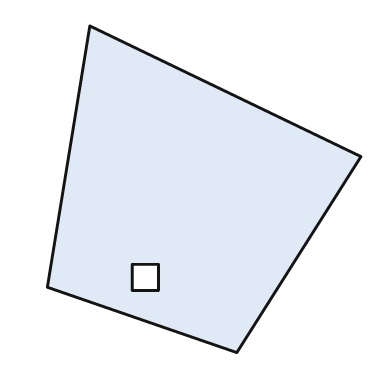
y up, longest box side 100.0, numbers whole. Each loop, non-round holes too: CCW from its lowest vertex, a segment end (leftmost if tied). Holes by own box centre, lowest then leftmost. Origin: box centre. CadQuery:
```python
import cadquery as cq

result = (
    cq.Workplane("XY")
    .moveTo(10.0, -50.0)
    .lineTo(48.0, 10.0)
    .lineTo(-35.0, 50.0)
    .lineTo(-48.0, -30.0)
    .close()
    .moveTo(-22.0, -31.0)
    .lineTo(-14.0, -31.0)
    .lineTo(-14.0, -23.0)
    .lineTo(-22.0, -23.0)
    .close()
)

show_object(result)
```